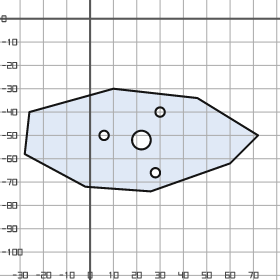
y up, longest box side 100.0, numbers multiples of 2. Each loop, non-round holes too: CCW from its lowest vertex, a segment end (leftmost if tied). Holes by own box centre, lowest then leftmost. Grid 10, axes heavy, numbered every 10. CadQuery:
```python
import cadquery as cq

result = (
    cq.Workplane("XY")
    .moveTo(26.0, -74.0)
    .lineTo(60.0, -62.0)
    .lineTo(72.0, -50.0)
    .lineTo(46.0, -34.0)
    .lineTo(10.0, -30.0)
    .lineTo(-26.0, -40.0)
    .lineTo(-28.0, -58.0)
    .lineTo(-2.0, -72.0)
    .close()
    .moveTo(28.0, -66.0)
    .circle(2.0)
    .moveTo(22.0, -52.0)
    .circle(4.0)
    .moveTo(6.0, -50.0)
    .circle(2.0)
    .moveTo(30.0, -40.0)
    .circle(2.0)
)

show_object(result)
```